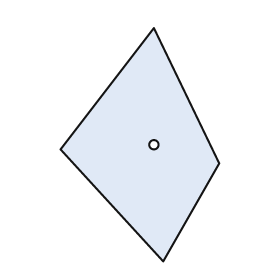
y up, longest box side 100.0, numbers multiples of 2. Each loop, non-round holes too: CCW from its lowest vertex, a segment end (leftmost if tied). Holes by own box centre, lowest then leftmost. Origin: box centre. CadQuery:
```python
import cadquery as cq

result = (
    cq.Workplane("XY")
    .moveTo(10.0, -50.0)
    .lineTo(34.0, -8.0)
    .lineTo(6.0, 50.0)
    .lineTo(-34.0, -2.0)
    .close()
    .moveTo(6.0, 0.0)
    .circle(2.0)
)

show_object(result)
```